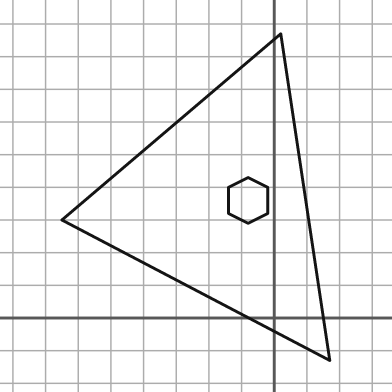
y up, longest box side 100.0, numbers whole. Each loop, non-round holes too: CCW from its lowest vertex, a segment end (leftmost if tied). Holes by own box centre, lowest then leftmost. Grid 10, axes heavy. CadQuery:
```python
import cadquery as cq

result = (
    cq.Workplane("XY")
    .moveTo(17.0, -13.0)
    .lineTo(2.0, 87.0)
    .lineTo(-65.0, 30.0)
    .close()
    .moveTo(-8.0, 29.0)
    .lineTo(-2.0, 32.0)
    .lineTo(-2.0, 40.0)
    .lineTo(-8.0, 43.0)
    .lineTo(-14.0, 40.0)
    .lineTo(-14.0, 32.0)
    .close()
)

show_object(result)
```